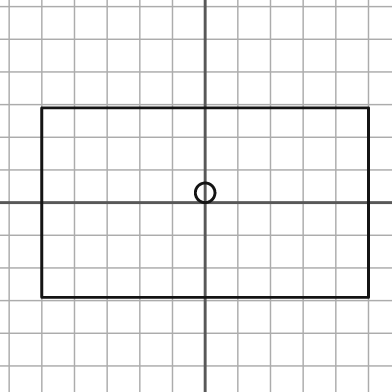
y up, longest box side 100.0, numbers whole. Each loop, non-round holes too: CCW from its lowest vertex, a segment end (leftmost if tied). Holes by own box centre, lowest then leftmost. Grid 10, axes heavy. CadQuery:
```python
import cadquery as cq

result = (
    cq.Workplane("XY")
    .moveTo(-50.0, -29.0)
    .lineTo(50.0, -29.0)
    .lineTo(50.0, 29.0)
    .lineTo(-50.0, 29.0)
    .close()
    .moveTo(0.0, 3.0)
    .circle(3.0)
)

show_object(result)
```